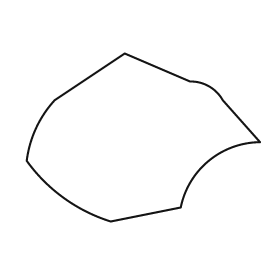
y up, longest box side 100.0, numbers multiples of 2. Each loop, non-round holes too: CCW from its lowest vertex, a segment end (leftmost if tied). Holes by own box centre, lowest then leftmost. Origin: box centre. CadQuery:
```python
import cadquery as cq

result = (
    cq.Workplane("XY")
    .moveTo(-14.0, -36.0)
    .lineTo(16.0, -30.0)
    .threePointArc((28.0, -10.0), (50.0, -2.0))
    .lineTo(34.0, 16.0)
    .threePointArc((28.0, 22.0), (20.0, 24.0))
    .lineTo(-8.0, 36.0)
    .lineTo(-38.0, 16.0)
    .threePointArc((-46.0, 4.0), (-50.0, -10.0))
    .threePointArc((-34.0, -26.0), (-14.0, -36.0))
    .close()
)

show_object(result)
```